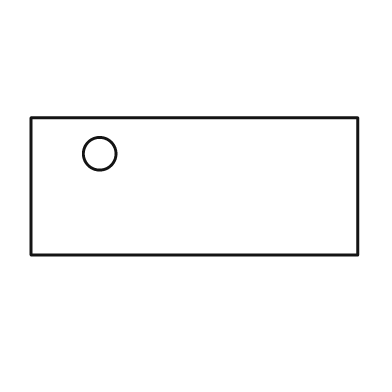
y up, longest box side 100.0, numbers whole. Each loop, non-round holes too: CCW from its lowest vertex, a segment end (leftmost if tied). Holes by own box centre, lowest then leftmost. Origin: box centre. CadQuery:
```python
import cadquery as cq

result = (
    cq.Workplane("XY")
    .moveTo(-50.0, -21.0)
    .lineTo(50.0, -21.0)
    .lineTo(50.0, 21.0)
    .lineTo(-50.0, 21.0)
    .close()
    .moveTo(-29.0, 10.0)
    .circle(5.0)
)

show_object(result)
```